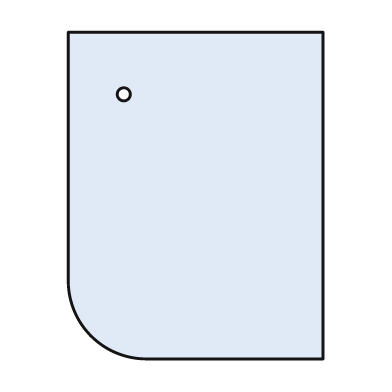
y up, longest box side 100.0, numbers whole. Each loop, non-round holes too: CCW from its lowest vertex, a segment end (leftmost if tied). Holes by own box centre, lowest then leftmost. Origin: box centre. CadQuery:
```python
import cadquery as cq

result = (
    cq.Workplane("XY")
    .moveTo(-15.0, -50.0)
    .lineTo(39.0, -50.0)
    .lineTo(39.0, 50.0)
    .lineTo(-39.0, 50.0)
    .lineTo(-39.0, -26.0)
    .threePointArc((-32.0, -43.0), (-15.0, -50.0))
    .close()
    .moveTo(-22.0, 31.0)
    .circle(2.0)
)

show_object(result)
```